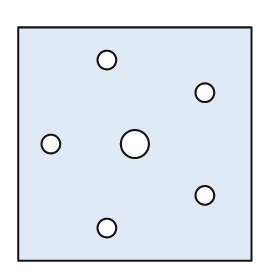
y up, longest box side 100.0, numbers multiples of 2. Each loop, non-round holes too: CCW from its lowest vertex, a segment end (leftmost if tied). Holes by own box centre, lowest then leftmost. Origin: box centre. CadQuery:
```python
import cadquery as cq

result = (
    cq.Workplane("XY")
    .moveTo(-50.0, -50.0)
    .lineTo(50.0, -50.0)
    .lineTo(50.0, 50.0)
    .lineTo(-50.0, 50.0)
    .close()
    .moveTo(-12.0, -36.0)
    .circle(4.0)
    .moveTo(30.0, -22.0)
    .circle(4.0)
    .moveTo(-36.0, 0.0)
    .circle(4.0)
    .moveTo(0.0, 0.0)
    .circle(6.0)
    .moveTo(30.0, 22.0)
    .circle(4.0)
    .moveTo(-12.0, 36.0)
    .circle(4.0)
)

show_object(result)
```